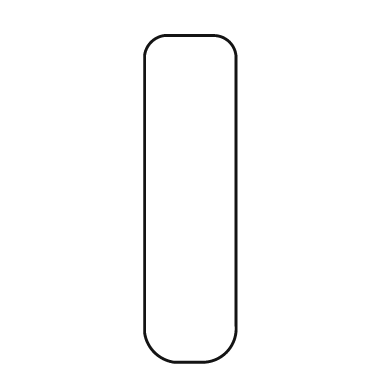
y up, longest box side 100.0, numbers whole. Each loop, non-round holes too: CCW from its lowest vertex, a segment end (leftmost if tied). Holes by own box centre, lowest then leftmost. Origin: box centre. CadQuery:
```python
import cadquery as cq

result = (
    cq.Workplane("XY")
    .moveTo(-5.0, -50.0)
    .lineTo(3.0, -50.0)
    .threePointArc((11.0, -47.0), (14.0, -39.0))
    .lineTo(14.0, 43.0)
    .threePointArc((12.0, 48.0), (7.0, 50.0))
    .lineTo(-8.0, 50.0)
    .threePointArc((-12.0, 48.0), (-14.0, 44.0))
    .lineTo(-14.0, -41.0)
    .threePointArc((-11.0, -47.0), (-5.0, -50.0))
    .close()
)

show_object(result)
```